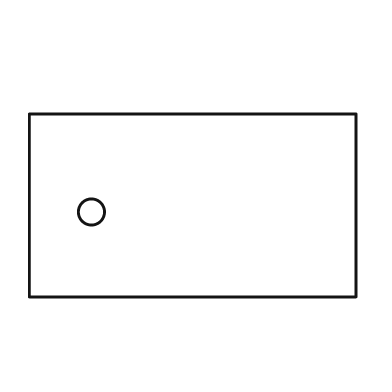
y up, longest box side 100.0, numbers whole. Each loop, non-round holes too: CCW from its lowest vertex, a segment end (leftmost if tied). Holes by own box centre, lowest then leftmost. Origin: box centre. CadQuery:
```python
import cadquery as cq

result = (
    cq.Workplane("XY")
    .moveTo(-50.0, -28.0)
    .lineTo(50.0, -28.0)
    .lineTo(50.0, 28.0)
    .lineTo(-50.0, 28.0)
    .close()
    .moveTo(-31.0, -2.0)
    .circle(4.0)
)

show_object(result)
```